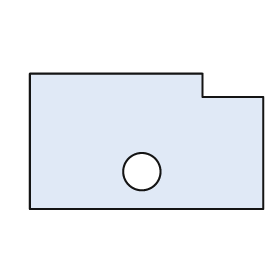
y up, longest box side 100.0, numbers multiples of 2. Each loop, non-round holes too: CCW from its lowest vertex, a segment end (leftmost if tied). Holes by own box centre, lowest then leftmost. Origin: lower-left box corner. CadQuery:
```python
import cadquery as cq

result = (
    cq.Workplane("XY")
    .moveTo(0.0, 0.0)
    .lineTo(100.0, 0.0)
    .lineTo(100.0, 48.0)
    .lineTo(74.0, 48.0)
    .lineTo(74.0, 58.0)
    .lineTo(0.0, 58.0)
    .close()
    .moveTo(48.0, 16.0)
    .circle(8.0)
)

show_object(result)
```